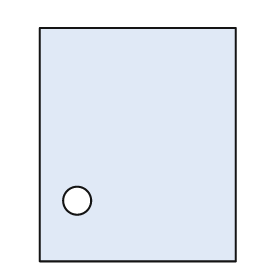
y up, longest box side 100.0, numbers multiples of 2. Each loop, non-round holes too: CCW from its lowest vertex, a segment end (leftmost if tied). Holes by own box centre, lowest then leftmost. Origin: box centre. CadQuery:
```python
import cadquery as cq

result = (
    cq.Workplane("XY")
    .moveTo(-42.0, -50.0)
    .lineTo(42.0, -50.0)
    .lineTo(42.0, 50.0)
    .lineTo(-42.0, 50.0)
    .close()
    .moveTo(-26.0, -24.0)
    .circle(6.0)
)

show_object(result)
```